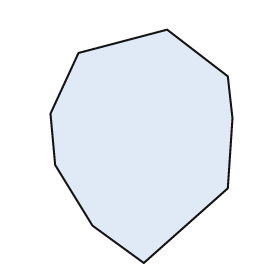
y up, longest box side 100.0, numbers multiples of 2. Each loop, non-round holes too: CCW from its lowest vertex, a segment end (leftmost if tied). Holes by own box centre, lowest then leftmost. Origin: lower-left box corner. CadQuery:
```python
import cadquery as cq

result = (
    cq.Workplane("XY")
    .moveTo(40.0, 0.0)
    .lineTo(76.0, 32.0)
    .lineTo(78.0, 62.0)
    .lineTo(76.0, 80.0)
    .lineTo(50.0, 100.0)
    .lineTo(12.0, 90.0)
    .lineTo(0.0, 64.0)
    .lineTo(2.0, 42.0)
    .lineTo(18.0, 16.0)
    .close()
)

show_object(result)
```